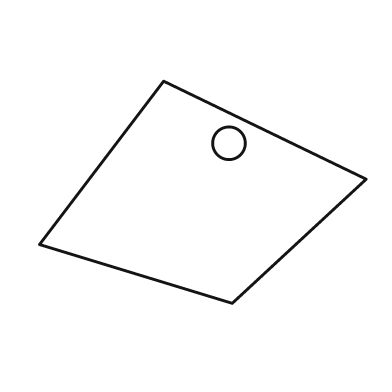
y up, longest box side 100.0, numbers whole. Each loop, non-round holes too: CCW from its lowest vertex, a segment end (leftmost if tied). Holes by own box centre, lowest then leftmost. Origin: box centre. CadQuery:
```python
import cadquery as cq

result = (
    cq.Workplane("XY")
    .moveTo(9.0, -34.0)
    .lineTo(50.0, 4.0)
    .lineTo(-12.0, 34.0)
    .lineTo(-50.0, -16.0)
    .close()
    .moveTo(8.0, 15.0)
    .circle(5.0)
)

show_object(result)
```